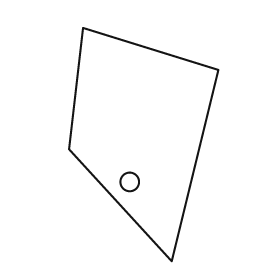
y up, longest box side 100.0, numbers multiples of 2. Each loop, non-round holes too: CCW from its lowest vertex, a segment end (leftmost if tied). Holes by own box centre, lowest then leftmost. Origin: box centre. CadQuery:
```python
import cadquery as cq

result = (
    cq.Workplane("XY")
    .moveTo(12.0, -50.0)
    .lineTo(32.0, 32.0)
    .lineTo(-26.0, 50.0)
    .lineTo(-32.0, -2.0)
    .close()
    .moveTo(-6.0, -16.0)
    .circle(4.0)
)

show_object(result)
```